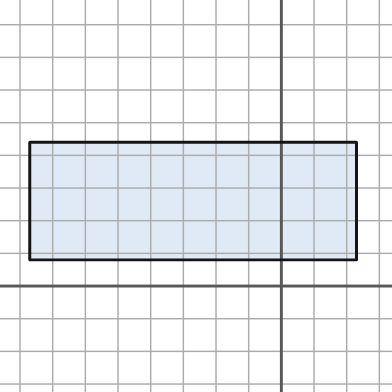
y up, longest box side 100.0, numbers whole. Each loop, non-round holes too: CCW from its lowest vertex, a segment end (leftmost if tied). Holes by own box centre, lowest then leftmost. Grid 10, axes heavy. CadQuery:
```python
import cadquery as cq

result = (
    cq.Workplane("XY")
    .moveTo(-77.0, 8.0)
    .lineTo(23.0, 8.0)
    .lineTo(23.0, 44.0)
    .lineTo(-77.0, 44.0)
    .close()
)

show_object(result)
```